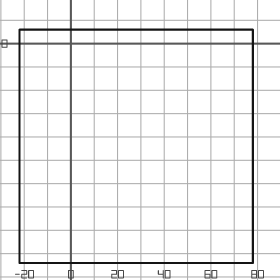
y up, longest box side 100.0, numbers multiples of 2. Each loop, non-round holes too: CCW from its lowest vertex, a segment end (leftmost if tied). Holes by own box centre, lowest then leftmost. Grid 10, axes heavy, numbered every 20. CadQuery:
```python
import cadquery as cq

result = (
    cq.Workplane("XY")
    .moveTo(-22.0, -94.0)
    .lineTo(78.0, -94.0)
    .lineTo(78.0, 6.0)
    .lineTo(-22.0, 6.0)
    .close()
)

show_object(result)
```